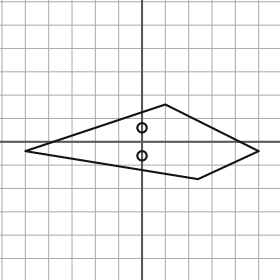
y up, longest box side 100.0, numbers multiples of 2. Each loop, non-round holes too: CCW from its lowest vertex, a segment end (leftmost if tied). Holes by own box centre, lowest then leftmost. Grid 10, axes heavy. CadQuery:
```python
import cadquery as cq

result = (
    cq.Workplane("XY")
    .moveTo(24.0, -16.0)
    .lineTo(50.0, -4.0)
    .lineTo(10.0, 16.0)
    .lineTo(-50.0, -4.0)
    .close()
    .moveTo(0.0, -6.0)
    .circle(2.0)
    .moveTo(0.0, 6.0)
    .circle(2.0)
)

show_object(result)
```